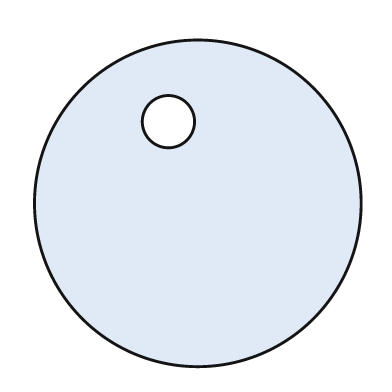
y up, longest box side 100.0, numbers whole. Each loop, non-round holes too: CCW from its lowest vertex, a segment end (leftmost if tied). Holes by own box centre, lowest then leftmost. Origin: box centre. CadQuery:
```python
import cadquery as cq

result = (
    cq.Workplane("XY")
    .moveTo(0.0, 0.0)
    .circle(50.0)
    .moveTo(-9.0, 25.0)
    .circle(8.0)
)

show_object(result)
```